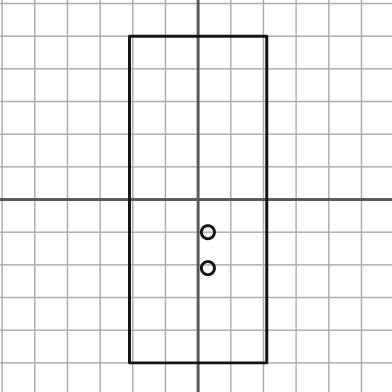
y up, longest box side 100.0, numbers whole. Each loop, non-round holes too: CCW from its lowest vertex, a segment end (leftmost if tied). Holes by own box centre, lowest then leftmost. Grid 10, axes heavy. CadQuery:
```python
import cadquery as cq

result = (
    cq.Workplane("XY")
    .moveTo(-21.0, -50.0)
    .lineTo(21.0, -50.0)
    .lineTo(21.0, 50.0)
    .lineTo(-21.0, 50.0)
    .close()
    .moveTo(3.0, -21.0)
    .circle(2.0)
    .moveTo(3.0, -10.0)
    .circle(2.0)
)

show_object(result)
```